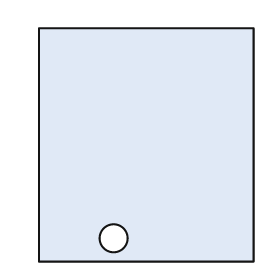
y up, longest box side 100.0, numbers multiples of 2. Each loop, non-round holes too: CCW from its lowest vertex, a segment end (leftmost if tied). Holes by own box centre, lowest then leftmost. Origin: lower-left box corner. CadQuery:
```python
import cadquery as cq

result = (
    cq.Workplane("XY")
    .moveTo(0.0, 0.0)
    .lineTo(92.0, 0.0)
    .lineTo(92.0, 100.0)
    .lineTo(0.0, 100.0)
    .close()
    .moveTo(32.0, 10.0)
    .circle(6.0)
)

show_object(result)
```